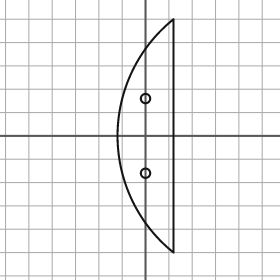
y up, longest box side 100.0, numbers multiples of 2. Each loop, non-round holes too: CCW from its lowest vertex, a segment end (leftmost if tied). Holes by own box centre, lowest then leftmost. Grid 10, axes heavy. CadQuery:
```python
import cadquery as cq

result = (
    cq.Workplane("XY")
    .moveTo(12.0, -50.0)
    .lineTo(12.0, 50.0)
    .threePointArc((-12.0, 0.0), (12.0, -50.0))
    .close()
    .moveTo(0.0, -16.0)
    .circle(2.0)
    .moveTo(0.0, 16.0)
    .circle(2.0)
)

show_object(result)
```